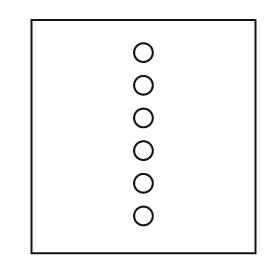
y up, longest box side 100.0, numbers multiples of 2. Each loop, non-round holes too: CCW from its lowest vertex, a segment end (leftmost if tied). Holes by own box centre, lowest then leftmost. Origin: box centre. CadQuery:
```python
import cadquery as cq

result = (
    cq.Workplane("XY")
    .moveTo(-48.0, -50.0)
    .lineTo(48.0, -50.0)
    .lineTo(48.0, 50.0)
    .lineTo(-48.0, 50.0)
    .close()
    .moveTo(0.0, -34.0)
    .circle(4.0)
    .moveTo(0.0, -20.0)
    .circle(4.0)
    .moveTo(0.0, -6.0)
    .circle(4.0)
    .moveTo(0.0, 8.0)
    .circle(4.0)
    .moveTo(0.0, 22.0)
    .circle(4.0)
    .moveTo(0.0, 36.0)
    .circle(4.0)
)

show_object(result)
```